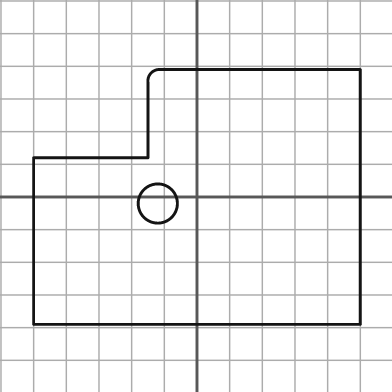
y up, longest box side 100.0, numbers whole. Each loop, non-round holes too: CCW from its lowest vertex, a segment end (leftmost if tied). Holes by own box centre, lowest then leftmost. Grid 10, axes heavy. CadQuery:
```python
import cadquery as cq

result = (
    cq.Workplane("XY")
    .moveTo(-50.0, -39.0)
    .lineTo(50.0, -39.0)
    .lineTo(50.0, 39.0)
    .lineTo(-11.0, 39.0)
    .threePointArc((-14.0, 38.0), (-15.0, 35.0))
    .lineTo(-15.0, 12.0)
    .lineTo(-50.0, 12.0)
    .close()
    .moveTo(-12.0, -2.0)
    .circle(6.0)
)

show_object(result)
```